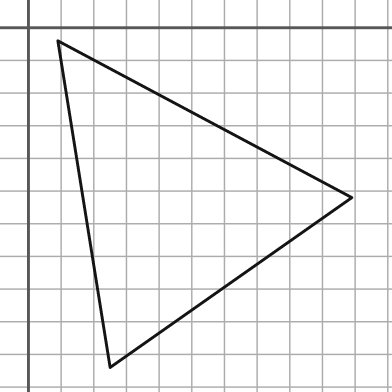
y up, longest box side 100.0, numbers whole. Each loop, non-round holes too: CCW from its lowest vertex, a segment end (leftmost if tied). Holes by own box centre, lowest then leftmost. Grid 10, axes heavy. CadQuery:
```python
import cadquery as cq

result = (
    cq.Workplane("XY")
    .moveTo(25.0, -104.0)
    .lineTo(99.0, -52.0)
    .lineTo(9.0, -4.0)
    .close()
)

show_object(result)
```